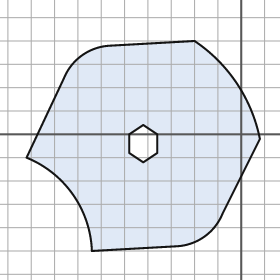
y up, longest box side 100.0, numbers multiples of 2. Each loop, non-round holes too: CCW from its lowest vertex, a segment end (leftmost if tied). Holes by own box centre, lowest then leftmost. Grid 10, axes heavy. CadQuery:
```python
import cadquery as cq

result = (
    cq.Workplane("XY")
    .moveTo(-64.0, -50.0)
    .lineTo(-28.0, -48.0)
    .threePointArc((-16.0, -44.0), (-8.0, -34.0))
    .lineTo(8.0, -2.0)
    .threePointArc((-2.0, 22.0), (-20.0, 40.0))
    .lineTo(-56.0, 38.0)
    .threePointArc((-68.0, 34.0), (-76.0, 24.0))
    .lineTo(-92.0, -10.0)
    .threePointArc((-72.0, -26.0), (-64.0, -50.0))
    .close()
    .moveTo(-42.0, -12.0)
    .lineTo(-36.0, -8.0)
    .lineTo(-36.0, 0.0)
    .lineTo(-42.0, 4.0)
    .lineTo(-48.0, 0.0)
    .lineTo(-48.0, -8.0)
    .close()
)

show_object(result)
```